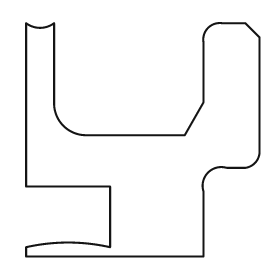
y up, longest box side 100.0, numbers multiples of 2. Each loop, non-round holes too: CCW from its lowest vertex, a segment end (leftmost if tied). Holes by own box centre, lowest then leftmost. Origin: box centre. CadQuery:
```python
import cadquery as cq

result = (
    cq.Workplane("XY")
    .moveTo(-50.0, -50.0)
    .lineTo(26.0, -50.0)
    .lineTo(26.0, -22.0)
    .threePointArc((28.0, -14.0), (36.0, -12.0))
    .lineTo(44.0, -12.0)
    .threePointArc((48.0, -10.0), (50.0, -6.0))
    .lineTo(50.0, 44.0)
    .lineTo(44.0, 50.0)
    .lineTo(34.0, 50.0)
    .threePointArc((28.0, 48.0), (26.0, 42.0))
    .lineTo(26.0, 16.0)
    .lineTo(18.0, 2.0)
    .lineTo(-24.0, 2.0)
    .threePointArc((-34.0, 6.0), (-38.0, 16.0))
    .lineTo(-38.0, 50.0)
    .threePointArc((-44.0, 48.0), (-50.0, 50.0))
    .lineTo(-50.0, -20.0)
    .lineTo(-14.0, -20.0)
    .lineTo(-14.0, -46.0)
    .threePointArc((-32.0, -44.0), (-50.0, -46.0))
    .close()
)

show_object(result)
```